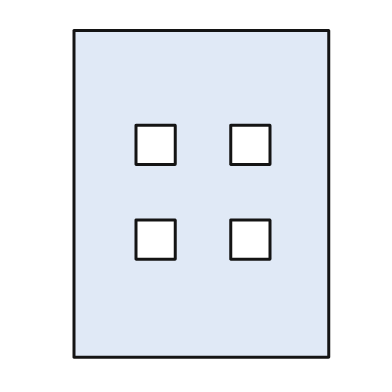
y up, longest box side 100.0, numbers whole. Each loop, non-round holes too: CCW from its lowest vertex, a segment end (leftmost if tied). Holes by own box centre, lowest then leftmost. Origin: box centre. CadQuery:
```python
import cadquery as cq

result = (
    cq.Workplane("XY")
    .moveTo(-39.0, -50.0)
    .lineTo(39.0, -50.0)
    .lineTo(39.0, 50.0)
    .lineTo(-39.0, 50.0)
    .close()
    .moveTo(-20.0, -20.0)
    .lineTo(-8.0, -20.0)
    .lineTo(-8.0, -8.0)
    .lineTo(-20.0, -8.0)
    .close()
    .moveTo(9.0, -20.0)
    .lineTo(21.0, -20.0)
    .lineTo(21.0, -8.0)
    .lineTo(9.0, -8.0)
    .close()
    .moveTo(-20.0, 9.0)
    .lineTo(-8.0, 9.0)
    .lineTo(-8.0, 21.0)
    .lineTo(-20.0, 21.0)
    .close()
    .moveTo(9.0, 9.0)
    .lineTo(21.0, 9.0)
    .lineTo(21.0, 21.0)
    .lineTo(9.0, 21.0)
    .close()
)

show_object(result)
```